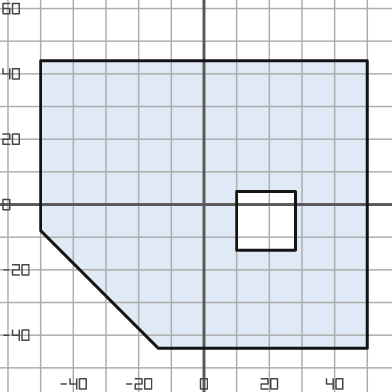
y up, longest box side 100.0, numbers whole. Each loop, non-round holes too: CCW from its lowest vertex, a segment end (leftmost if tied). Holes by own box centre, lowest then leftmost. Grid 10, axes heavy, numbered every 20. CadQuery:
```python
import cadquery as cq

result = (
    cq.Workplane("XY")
    .moveTo(-14.0, -44.0)
    .lineTo(50.0, -44.0)
    .lineTo(50.0, 44.0)
    .lineTo(-50.0, 44.0)
    .lineTo(-50.0, -8.0)
    .close()
    .moveTo(10.0, -14.0)
    .lineTo(28.0, -14.0)
    .lineTo(28.0, 4.0)
    .lineTo(10.0, 4.0)
    .close()
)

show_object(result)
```